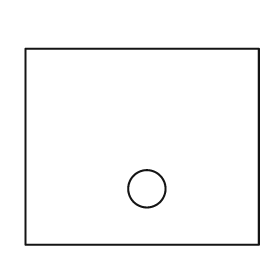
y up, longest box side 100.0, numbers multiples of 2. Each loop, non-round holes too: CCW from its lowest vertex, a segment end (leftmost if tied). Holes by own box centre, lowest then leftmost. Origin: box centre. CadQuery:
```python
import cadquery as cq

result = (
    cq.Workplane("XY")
    .moveTo(-50.0, -42.0)
    .lineTo(50.0, -42.0)
    .lineTo(50.0, 42.0)
    .lineTo(-50.0, 42.0)
    .close()
    .moveTo(2.0, -18.0)
    .circle(8.0)
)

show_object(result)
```